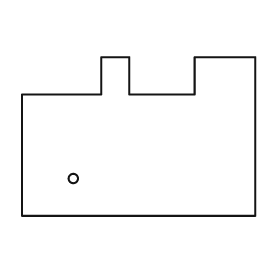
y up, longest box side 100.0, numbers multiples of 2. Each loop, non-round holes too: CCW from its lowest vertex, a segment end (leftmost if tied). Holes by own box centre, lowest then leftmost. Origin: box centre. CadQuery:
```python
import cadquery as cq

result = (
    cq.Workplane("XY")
    .moveTo(-50.0, -34.0)
    .lineTo(50.0, -34.0)
    .lineTo(50.0, 34.0)
    .lineTo(24.0, 34.0)
    .lineTo(24.0, 18.0)
    .lineTo(-4.0, 18.0)
    .lineTo(-4.0, 34.0)
    .lineTo(-16.0, 34.0)
    .lineTo(-16.0, 18.0)
    .lineTo(-50.0, 18.0)
    .close()
    .moveTo(-28.0, -18.0)
    .circle(2.0)
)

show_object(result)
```